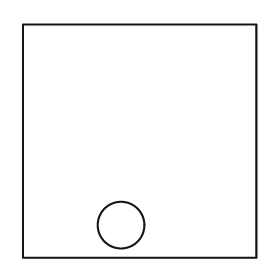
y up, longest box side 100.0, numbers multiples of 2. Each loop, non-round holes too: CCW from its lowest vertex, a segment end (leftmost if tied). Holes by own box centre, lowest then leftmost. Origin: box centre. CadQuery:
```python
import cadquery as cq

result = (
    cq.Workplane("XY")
    .moveTo(-50.0, -50.0)
    .lineTo(50.0, -50.0)
    .lineTo(50.0, 50.0)
    .lineTo(-50.0, 50.0)
    .close()
    .moveTo(-8.0, -36.0)
    .circle(10.0)
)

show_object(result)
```